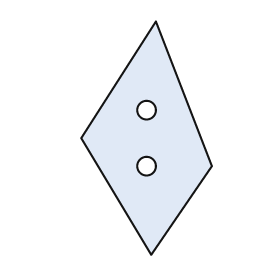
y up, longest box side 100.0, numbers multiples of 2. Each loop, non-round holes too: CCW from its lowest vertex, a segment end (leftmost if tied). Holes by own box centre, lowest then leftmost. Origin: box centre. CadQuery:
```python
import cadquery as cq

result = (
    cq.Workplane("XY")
    .moveTo(2.0, -50.0)
    .lineTo(28.0, -12.0)
    .lineTo(4.0, 50.0)
    .lineTo(-28.0, 0.0)
    .close()
    .moveTo(0.0, -12.0)
    .circle(4.0)
    .moveTo(0.0, 12.0)
    .circle(4.0)
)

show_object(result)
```